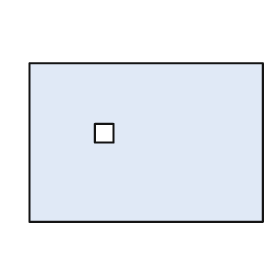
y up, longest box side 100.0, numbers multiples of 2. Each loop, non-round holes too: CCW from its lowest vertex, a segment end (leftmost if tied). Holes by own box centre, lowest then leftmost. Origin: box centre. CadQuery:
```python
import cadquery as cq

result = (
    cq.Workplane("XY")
    .moveTo(-50.0, -34.0)
    .lineTo(50.0, -34.0)
    .lineTo(50.0, 34.0)
    .lineTo(-50.0, 34.0)
    .close()
    .moveTo(-22.0, 0.0)
    .lineTo(-14.0, 0.0)
    .lineTo(-14.0, 8.0)
    .lineTo(-22.0, 8.0)
    .close()
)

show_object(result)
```